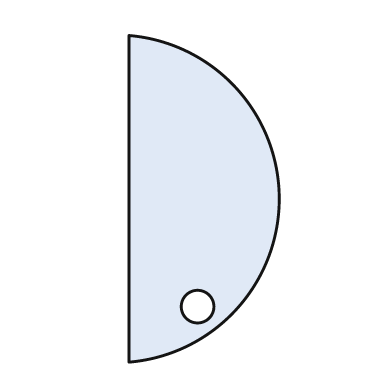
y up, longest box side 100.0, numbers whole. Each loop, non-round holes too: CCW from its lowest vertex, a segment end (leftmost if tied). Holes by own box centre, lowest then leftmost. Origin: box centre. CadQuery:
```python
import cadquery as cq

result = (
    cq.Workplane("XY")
    .moveTo(-23.0, -50.0)
    .threePointArc((23.0, 0.0), (-23.0, 50.0))
    .close()
    .moveTo(-2.0, -33.0)
    .circle(5.0)
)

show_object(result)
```